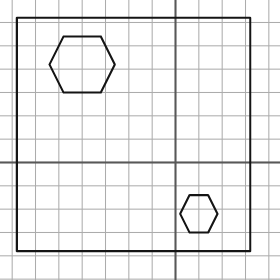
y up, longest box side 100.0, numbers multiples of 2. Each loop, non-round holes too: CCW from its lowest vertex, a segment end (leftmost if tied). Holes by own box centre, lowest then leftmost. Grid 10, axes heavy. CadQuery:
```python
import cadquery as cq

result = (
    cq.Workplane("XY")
    .moveTo(-68.0, -38.0)
    .lineTo(32.0, -38.0)
    .lineTo(32.0, 62.0)
    .lineTo(-68.0, 62.0)
    .close()
    .moveTo(6.0, -30.0)
    .lineTo(14.0, -30.0)
    .lineTo(18.0, -22.0)
    .lineTo(14.0, -14.0)
    .lineTo(6.0, -14.0)
    .lineTo(2.0, -22.0)
    .close()
    .moveTo(-48.0, 30.0)
    .lineTo(-32.0, 30.0)
    .lineTo(-26.0, 42.0)
    .lineTo(-32.0, 54.0)
    .lineTo(-48.0, 54.0)
    .lineTo(-54.0, 42.0)
    .close()
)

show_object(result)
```